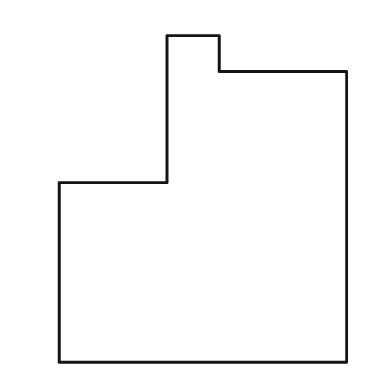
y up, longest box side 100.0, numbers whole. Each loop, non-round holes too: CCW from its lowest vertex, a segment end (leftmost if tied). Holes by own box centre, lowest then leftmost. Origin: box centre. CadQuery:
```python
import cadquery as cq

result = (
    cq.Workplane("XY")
    .moveTo(-44.0, -50.0)
    .lineTo(44.0, -50.0)
    .lineTo(44.0, 39.0)
    .lineTo(5.0, 39.0)
    .lineTo(5.0, 50.0)
    .lineTo(-11.0, 50.0)
    .lineTo(-11.0, 5.0)
    .lineTo(-44.0, 5.0)
    .close()
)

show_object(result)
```